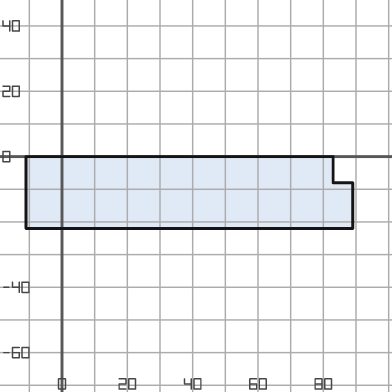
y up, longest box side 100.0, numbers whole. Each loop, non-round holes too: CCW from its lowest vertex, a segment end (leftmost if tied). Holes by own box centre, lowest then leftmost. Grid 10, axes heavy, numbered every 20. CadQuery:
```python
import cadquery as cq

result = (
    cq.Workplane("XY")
    .moveTo(-11.0, -22.0)
    .lineTo(89.0, -22.0)
    .lineTo(89.0, -8.0)
    .lineTo(83.0, -8.0)
    .lineTo(83.0, 0.0)
    .lineTo(-11.0, 0.0)
    .close()
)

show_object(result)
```